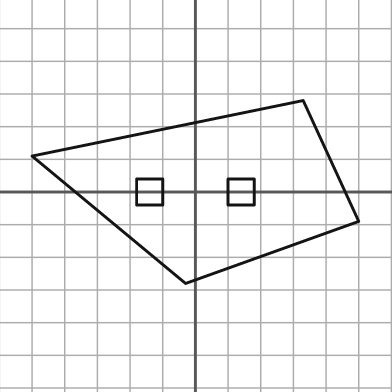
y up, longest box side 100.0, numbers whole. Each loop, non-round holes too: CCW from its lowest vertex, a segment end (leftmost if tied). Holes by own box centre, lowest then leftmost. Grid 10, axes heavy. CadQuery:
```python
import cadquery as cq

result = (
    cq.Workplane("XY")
    .moveTo(-3.0, -28.0)
    .lineTo(50.0, -9.0)
    .lineTo(33.0, 28.0)
    .lineTo(-50.0, 11.0)
    .close()
    .moveTo(-18.0, -4.0)
    .lineTo(-10.0, -4.0)
    .lineTo(-10.0, 4.0)
    .lineTo(-18.0, 4.0)
    .close()
    .moveTo(10.0, -4.0)
    .lineTo(18.0, -4.0)
    .lineTo(18.0, 4.0)
    .lineTo(10.0, 4.0)
    .close()
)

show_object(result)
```